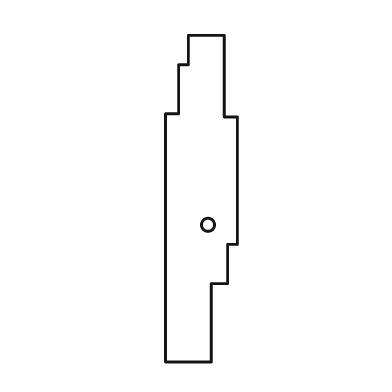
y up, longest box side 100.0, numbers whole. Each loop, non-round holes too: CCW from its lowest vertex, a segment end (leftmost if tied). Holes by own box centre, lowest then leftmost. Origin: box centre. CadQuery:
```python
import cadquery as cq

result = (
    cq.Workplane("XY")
    .moveTo(-11.0, -50.0)
    .lineTo(3.0, -50.0)
    .lineTo(3.0, -26.0)
    .lineTo(8.0, -26.0)
    .lineTo(8.0, -14.0)
    .lineTo(11.0, -14.0)
    .lineTo(11.0, 25.0)
    .lineTo(7.0, 25.0)
    .lineTo(7.0, 50.0)
    .lineTo(-4.0, 50.0)
    .lineTo(-4.0, 41.0)
    .lineTo(-7.0, 41.0)
    .lineTo(-7.0, 26.0)
    .lineTo(-11.0, 26.0)
    .close()
    .moveTo(2.0, -8.0)
    .circle(2.0)
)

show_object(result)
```